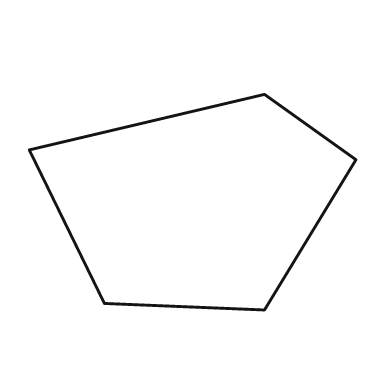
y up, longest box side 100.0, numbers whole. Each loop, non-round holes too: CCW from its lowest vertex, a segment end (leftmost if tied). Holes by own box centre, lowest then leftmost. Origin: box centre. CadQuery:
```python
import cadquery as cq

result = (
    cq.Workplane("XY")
    .moveTo(22.0, -33.0)
    .lineTo(50.0, 13.0)
    .lineTo(22.0, 33.0)
    .lineTo(-50.0, 16.0)
    .lineTo(-27.0, -31.0)
    .close()
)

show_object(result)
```